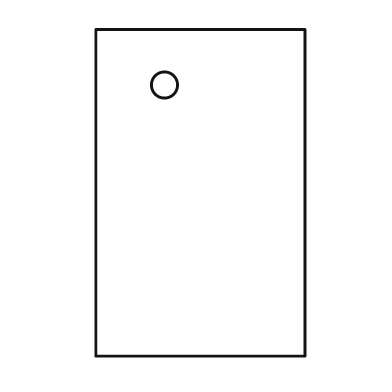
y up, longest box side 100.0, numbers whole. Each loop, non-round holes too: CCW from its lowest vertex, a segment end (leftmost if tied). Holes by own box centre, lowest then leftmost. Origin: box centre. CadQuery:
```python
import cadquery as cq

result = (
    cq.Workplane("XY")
    .moveTo(-32.0, -50.0)
    .lineTo(32.0, -50.0)
    .lineTo(32.0, 50.0)
    .lineTo(-32.0, 50.0)
    .close()
    .moveTo(-11.0, 33.0)
    .circle(4.0)
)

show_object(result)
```